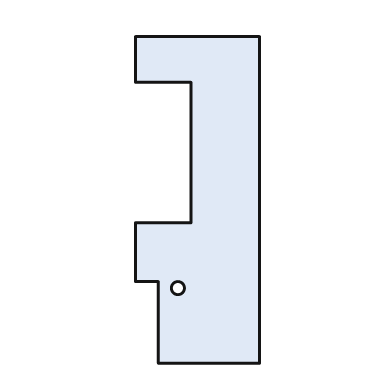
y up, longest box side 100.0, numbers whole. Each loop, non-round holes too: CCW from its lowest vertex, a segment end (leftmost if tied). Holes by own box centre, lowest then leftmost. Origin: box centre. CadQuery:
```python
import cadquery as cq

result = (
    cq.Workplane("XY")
    .moveTo(-12.0, -50.0)
    .lineTo(19.0, -50.0)
    .lineTo(19.0, 50.0)
    .lineTo(-19.0, 50.0)
    .lineTo(-19.0, 36.0)
    .lineTo(-2.0, 36.0)
    .lineTo(-2.0, -7.0)
    .lineTo(-19.0, -7.0)
    .lineTo(-19.0, -25.0)
    .lineTo(-12.0, -25.0)
    .close()
    .moveTo(-6.0, -27.0)
    .circle(2.0)
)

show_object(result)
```